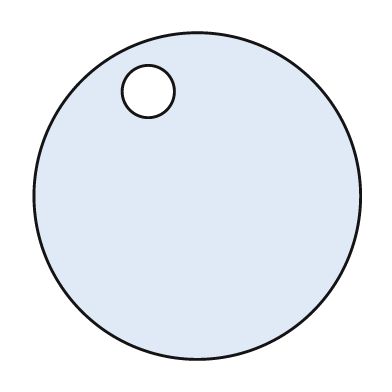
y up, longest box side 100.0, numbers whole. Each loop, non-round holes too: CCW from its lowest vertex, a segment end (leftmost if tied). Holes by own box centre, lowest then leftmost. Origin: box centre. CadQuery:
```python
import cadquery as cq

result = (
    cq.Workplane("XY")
    .moveTo(0.0, 0.0)
    .circle(50.0)
    .moveTo(-15.0, 32.0)
    .circle(8.0)
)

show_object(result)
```